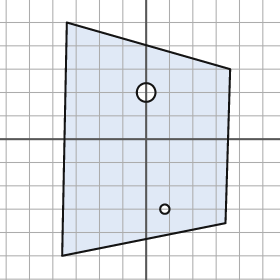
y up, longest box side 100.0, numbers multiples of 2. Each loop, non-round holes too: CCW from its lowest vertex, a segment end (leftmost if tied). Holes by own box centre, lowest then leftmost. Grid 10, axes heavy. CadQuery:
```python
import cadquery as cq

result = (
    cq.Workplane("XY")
    .moveTo(-36.0, -50.0)
    .lineTo(34.0, -36.0)
    .lineTo(36.0, 30.0)
    .lineTo(-34.0, 50.0)
    .close()
    .moveTo(8.0, -30.0)
    .circle(2.0)
    .moveTo(0.0, 20.0)
    .circle(4.0)
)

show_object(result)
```